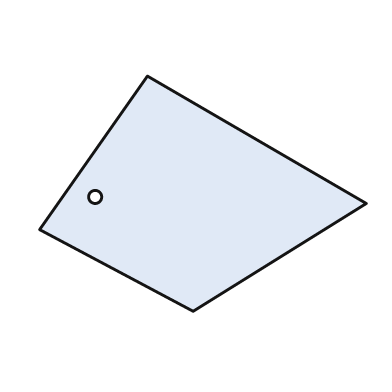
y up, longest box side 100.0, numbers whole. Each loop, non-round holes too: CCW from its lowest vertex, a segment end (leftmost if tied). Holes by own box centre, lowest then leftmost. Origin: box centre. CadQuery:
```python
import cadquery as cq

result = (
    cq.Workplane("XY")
    .moveTo(-3.0, -36.0)
    .lineTo(50.0, -3.0)
    .lineTo(-17.0, 36.0)
    .lineTo(-50.0, -11.0)
    .close()
    .moveTo(-33.0, -1.0)
    .circle(2.0)
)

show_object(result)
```